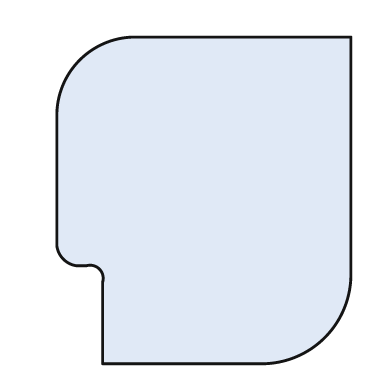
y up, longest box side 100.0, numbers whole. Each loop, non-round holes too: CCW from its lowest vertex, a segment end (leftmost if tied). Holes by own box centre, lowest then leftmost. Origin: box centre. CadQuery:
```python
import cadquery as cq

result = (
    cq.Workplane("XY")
    .moveTo(-31.0, -50.0)
    .lineTo(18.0, -50.0)
    .threePointArc((37.0, -42.0), (45.0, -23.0))
    .lineTo(45.0, 50.0)
    .lineTo(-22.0, 50.0)
    .threePointArc((-38.0, 43.0), (-45.0, 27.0))
    .lineTo(-45.0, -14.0)
    .threePointArc((-43.0, -18.0), (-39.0, -20.0))
    .lineTo(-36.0, -20.0)
    .threePointArc((-32.0, -21.0), (-31.0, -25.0))
    .close()
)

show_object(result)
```